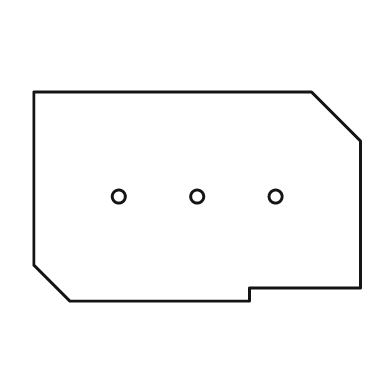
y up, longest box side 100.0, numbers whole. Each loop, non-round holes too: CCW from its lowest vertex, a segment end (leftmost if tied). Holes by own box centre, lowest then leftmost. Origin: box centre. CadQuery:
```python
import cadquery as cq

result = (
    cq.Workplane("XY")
    .moveTo(-39.0, -32.0)
    .lineTo(16.0, -32.0)
    .lineTo(16.0, -28.0)
    .lineTo(50.0, -28.0)
    .lineTo(50.0, 17.0)
    .lineTo(35.0, 32.0)
    .lineTo(-50.0, 32.0)
    .lineTo(-50.0, -21.0)
    .close()
    .moveTo(-24.0, 0.0)
    .circle(2.0)
    .moveTo(0.0, 0.0)
    .circle(2.0)
    .moveTo(24.0, 0.0)
    .circle(2.0)
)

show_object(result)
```